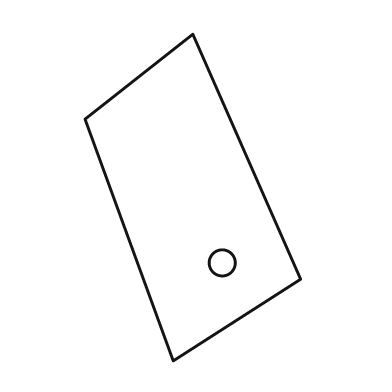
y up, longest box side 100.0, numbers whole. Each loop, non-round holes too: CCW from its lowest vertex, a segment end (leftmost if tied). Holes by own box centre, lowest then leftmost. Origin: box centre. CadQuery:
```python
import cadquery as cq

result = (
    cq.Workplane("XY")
    .moveTo(-6.0, -50.0)
    .lineTo(33.0, -25.0)
    .lineTo(0.0, 50.0)
    .lineTo(-33.0, 24.0)
    .close()
    .moveTo(9.0, -20.0)
    .circle(4.0)
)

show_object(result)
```